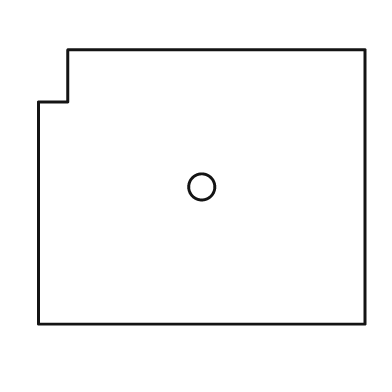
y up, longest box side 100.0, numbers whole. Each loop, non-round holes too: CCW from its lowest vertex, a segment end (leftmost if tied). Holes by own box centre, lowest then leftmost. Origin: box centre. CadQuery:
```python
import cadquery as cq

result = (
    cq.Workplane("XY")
    .moveTo(-50.0, -42.0)
    .lineTo(50.0, -42.0)
    .lineTo(50.0, 42.0)
    .lineTo(-41.0, 42.0)
    .lineTo(-41.0, 26.0)
    .lineTo(-50.0, 26.0)
    .close()
    .moveTo(0.0, 0.0)
    .circle(4.0)
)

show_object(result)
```